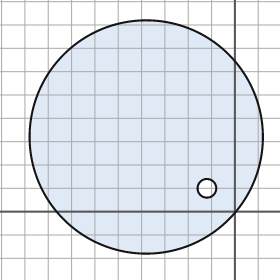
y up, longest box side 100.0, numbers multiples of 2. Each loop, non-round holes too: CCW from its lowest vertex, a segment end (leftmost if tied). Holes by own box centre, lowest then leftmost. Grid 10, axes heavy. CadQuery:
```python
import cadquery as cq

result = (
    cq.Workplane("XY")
    .moveTo(-38.0, 32.0)
    .circle(50.0)
    .moveTo(-12.0, 10.0)
    .circle(4.0)
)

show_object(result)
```